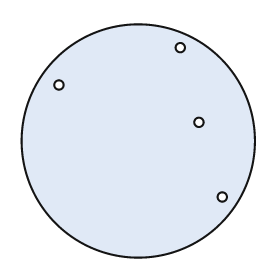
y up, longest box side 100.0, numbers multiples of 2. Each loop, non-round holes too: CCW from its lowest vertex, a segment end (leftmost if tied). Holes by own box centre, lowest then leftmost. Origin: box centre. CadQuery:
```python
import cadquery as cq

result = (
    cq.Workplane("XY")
    .moveTo(0.0, 0.0)
    .circle(50.0)
    .moveTo(36.0, -24.0)
    .circle(2.0)
    .moveTo(26.0, 8.0)
    .circle(2.0)
    .moveTo(-34.0, 24.0)
    .circle(2.0)
    .moveTo(18.0, 40.0)
    .circle(2.0)
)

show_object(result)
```